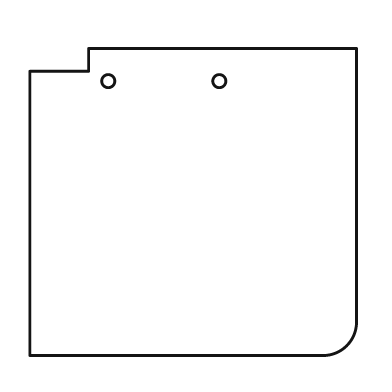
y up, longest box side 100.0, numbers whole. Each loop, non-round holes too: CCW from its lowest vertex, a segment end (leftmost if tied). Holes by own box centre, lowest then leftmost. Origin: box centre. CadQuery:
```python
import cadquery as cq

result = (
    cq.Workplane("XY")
    .moveTo(-50.0, -47.0)
    .lineTo(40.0, -47.0)
    .threePointArc((47.0, -44.0), (50.0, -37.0))
    .lineTo(50.0, 47.0)
    .lineTo(-32.0, 47.0)
    .lineTo(-32.0, 40.0)
    .lineTo(-50.0, 40.0)
    .close()
    .moveTo(-26.0, 37.0)
    .circle(2.0)
    .moveTo(8.0, 37.0)
    .circle(2.0)
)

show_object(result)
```